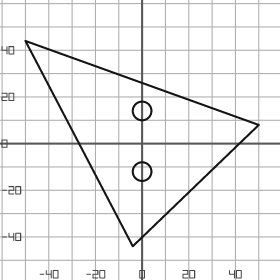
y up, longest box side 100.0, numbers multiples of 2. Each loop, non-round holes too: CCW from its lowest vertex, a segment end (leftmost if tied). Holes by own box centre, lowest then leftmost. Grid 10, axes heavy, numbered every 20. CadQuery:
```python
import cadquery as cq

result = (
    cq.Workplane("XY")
    .moveTo(-4.0, -44.0)
    .lineTo(50.0, 8.0)
    .lineTo(-50.0, 44.0)
    .close()
    .moveTo(0.0, -12.0)
    .circle(4.0)
    .moveTo(0.0, 14.0)
    .circle(4.0)
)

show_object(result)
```